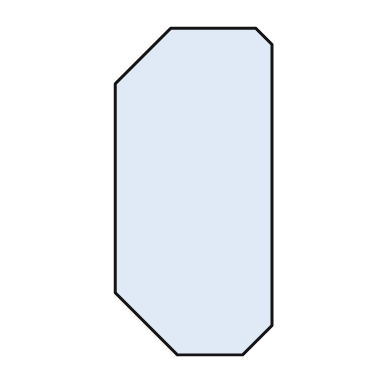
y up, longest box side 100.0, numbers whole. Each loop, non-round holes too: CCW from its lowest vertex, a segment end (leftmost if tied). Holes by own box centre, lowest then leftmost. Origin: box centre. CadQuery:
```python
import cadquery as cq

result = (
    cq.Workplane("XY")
    .moveTo(-5.0, -50.0)
    .lineTo(15.0, -50.0)
    .lineTo(24.0, -41.0)
    .lineTo(24.0, 45.0)
    .lineTo(19.0, 50.0)
    .lineTo(-7.0, 50.0)
    .lineTo(-24.0, 33.0)
    .lineTo(-24.0, -31.0)
    .close()
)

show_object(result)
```